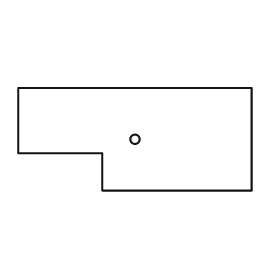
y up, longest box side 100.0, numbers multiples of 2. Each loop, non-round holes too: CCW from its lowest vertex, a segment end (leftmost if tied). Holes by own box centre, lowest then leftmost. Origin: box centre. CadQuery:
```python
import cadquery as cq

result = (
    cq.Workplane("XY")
    .moveTo(-14.0, -22.0)
    .lineTo(50.0, -22.0)
    .lineTo(50.0, 22.0)
    .lineTo(-50.0, 22.0)
    .lineTo(-50.0, -6.0)
    .lineTo(-14.0, -6.0)
    .close()
    .moveTo(0.0, 0.0)
    .circle(2.0)
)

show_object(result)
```